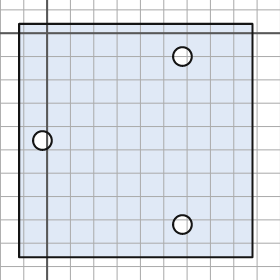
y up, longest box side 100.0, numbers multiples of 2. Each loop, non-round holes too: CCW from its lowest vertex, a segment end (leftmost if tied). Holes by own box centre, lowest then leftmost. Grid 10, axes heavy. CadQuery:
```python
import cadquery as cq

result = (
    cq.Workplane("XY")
    .moveTo(-12.0, -96.0)
    .lineTo(88.0, -96.0)
    .lineTo(88.0, 4.0)
    .lineTo(-12.0, 4.0)
    .close()
    .moveTo(58.0, -82.0)
    .circle(4.0)
    .moveTo(-2.0, -46.0)
    .circle(4.0)
    .moveTo(58.0, -10.0)
    .circle(4.0)
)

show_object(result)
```